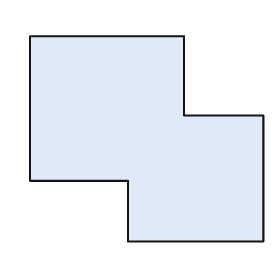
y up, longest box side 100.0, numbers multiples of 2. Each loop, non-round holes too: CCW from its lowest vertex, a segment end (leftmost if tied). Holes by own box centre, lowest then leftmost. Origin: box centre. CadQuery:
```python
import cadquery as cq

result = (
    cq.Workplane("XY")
    .moveTo(-8.0, -44.0)
    .lineTo(50.0, -44.0)
    .lineTo(50.0, 10.0)
    .lineTo(16.0, 10.0)
    .lineTo(16.0, 44.0)
    .lineTo(-50.0, 44.0)
    .lineTo(-50.0, -18.0)
    .lineTo(-8.0, -18.0)
    .close()
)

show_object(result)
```